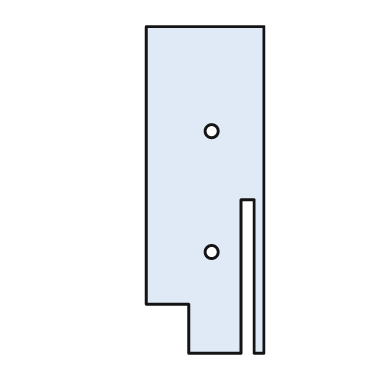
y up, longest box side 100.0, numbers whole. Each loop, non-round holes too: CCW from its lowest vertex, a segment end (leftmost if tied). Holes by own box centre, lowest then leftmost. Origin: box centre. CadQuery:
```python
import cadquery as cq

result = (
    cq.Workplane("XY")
    .moveTo(-5.0, -50.0)
    .lineTo(11.0, -50.0)
    .lineTo(11.0, -3.0)
    .lineTo(15.0, -3.0)
    .lineTo(15.0, -50.0)
    .lineTo(18.0, -50.0)
    .lineTo(18.0, 50.0)
    .lineTo(-18.0, 50.0)
    .lineTo(-18.0, -35.0)
    .lineTo(-5.0, -35.0)
    .close()
    .moveTo(2.0, -19.0)
    .circle(2.0)
    .moveTo(2.0, 18.0)
    .circle(2.0)
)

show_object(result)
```